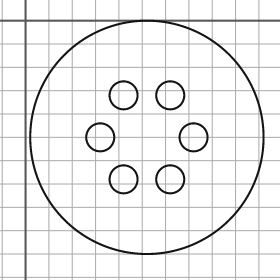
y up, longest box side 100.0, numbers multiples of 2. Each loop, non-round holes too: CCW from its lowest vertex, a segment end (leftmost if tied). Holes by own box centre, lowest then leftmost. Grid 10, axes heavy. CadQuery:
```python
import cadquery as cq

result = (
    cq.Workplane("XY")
    .moveTo(52.0, -50.0)
    .circle(50.0)
    .moveTo(42.0, -68.0)
    .circle(6.0)
    .moveTo(62.0, -68.0)
    .circle(6.0)
    .moveTo(32.0, -50.0)
    .circle(6.0)
    .moveTo(72.0, -50.0)
    .circle(6.0)
    .moveTo(42.0, -32.0)
    .circle(6.0)
    .moveTo(62.0, -32.0)
    .circle(6.0)
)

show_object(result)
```